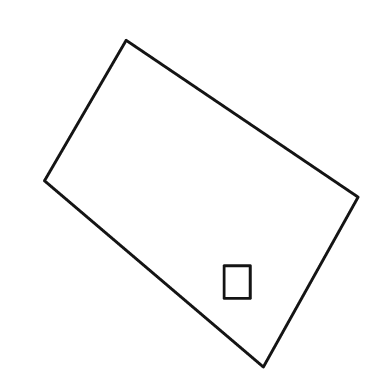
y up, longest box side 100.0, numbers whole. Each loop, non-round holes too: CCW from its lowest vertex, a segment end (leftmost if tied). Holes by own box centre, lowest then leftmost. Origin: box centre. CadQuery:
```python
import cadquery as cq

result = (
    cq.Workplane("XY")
    .moveTo(19.0, -50.0)
    .lineTo(48.0, 2.0)
    .lineTo(-23.0, 50.0)
    .lineTo(-48.0, 7.0)
    .close()
    .moveTo(7.0, -29.0)
    .lineTo(15.0, -29.0)
    .lineTo(15.0, -19.0)
    .lineTo(7.0, -19.0)
    .close()
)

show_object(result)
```